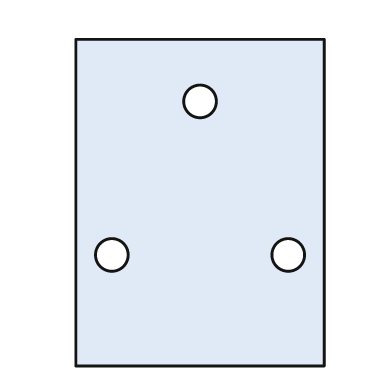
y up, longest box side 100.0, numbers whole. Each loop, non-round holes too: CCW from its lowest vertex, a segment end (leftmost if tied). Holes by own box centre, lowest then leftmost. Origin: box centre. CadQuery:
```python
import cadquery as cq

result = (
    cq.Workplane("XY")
    .moveTo(-38.0, -50.0)
    .lineTo(38.0, -50.0)
    .lineTo(38.0, 50.0)
    .lineTo(-38.0, 50.0)
    .close()
    .moveTo(-27.0, -16.0)
    .circle(5.0)
    .moveTo(27.0, -16.0)
    .circle(5.0)
    .moveTo(0.0, 31.0)
    .circle(5.0)
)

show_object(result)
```